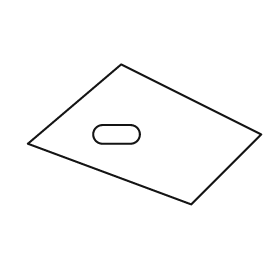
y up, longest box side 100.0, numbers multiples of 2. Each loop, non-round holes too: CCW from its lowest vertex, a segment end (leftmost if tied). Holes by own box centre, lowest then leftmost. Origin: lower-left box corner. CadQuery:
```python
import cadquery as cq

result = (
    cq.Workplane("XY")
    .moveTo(70.0, 0.0)
    .lineTo(100.0, 30.0)
    .lineTo(40.0, 60.0)
    .lineTo(0.0, 26.0)
    .close()
    .moveTo(32.0, 26.0)
    .lineTo(44.0, 26.0)
    .threePointArc((48.0, 30.0), (44.0, 34.0))
    .lineTo(32.0, 34.0)
    .threePointArc((28.0, 30.0), (32.0, 26.0))
    .close()
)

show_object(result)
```